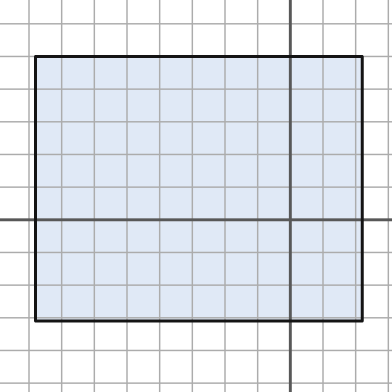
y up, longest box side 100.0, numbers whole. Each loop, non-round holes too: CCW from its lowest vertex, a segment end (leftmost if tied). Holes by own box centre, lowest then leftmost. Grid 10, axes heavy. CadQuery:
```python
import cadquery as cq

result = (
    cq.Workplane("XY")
    .moveTo(-78.0, -31.0)
    .lineTo(22.0, -31.0)
    .lineTo(22.0, 50.0)
    .lineTo(-78.0, 50.0)
    .close()
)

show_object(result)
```